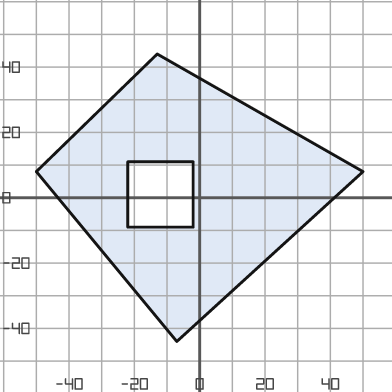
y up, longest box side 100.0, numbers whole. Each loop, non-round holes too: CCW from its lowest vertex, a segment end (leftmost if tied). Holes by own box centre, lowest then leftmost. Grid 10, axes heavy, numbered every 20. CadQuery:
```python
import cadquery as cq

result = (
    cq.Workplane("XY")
    .moveTo(-7.0, -44.0)
    .lineTo(50.0, 8.0)
    .lineTo(-13.0, 44.0)
    .lineTo(-50.0, 8.0)
    .close()
    .moveTo(-22.0, -9.0)
    .lineTo(-2.0, -9.0)
    .lineTo(-2.0, 11.0)
    .lineTo(-22.0, 11.0)
    .close()
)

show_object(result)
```